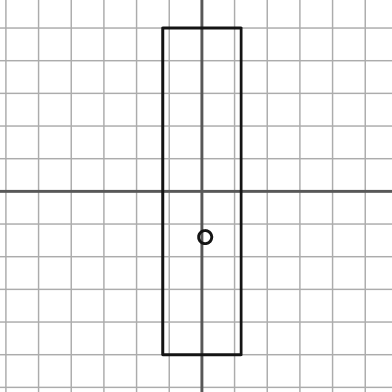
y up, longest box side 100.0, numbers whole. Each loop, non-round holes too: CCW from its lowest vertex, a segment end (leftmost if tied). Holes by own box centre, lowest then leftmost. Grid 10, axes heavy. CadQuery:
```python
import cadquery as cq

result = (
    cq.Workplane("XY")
    .moveTo(-12.0, -50.0)
    .lineTo(12.0, -50.0)
    .lineTo(12.0, 50.0)
    .lineTo(-12.0, 50.0)
    .close()
    .moveTo(1.0, -14.0)
    .circle(2.0)
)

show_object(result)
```